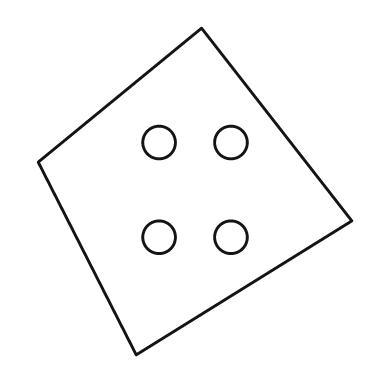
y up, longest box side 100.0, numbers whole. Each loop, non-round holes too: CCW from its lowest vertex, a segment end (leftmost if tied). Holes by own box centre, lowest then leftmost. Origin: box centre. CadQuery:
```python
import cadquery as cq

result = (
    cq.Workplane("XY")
    .moveTo(-18.0, -50.0)
    .lineTo(48.0, -9.0)
    .lineTo(2.0, 50.0)
    .lineTo(-48.0, 9.0)
    .close()
    .moveTo(-11.0, -14.0)
    .circle(5.0)
    .moveTo(11.0, -14.0)
    .circle(5.0)
    .moveTo(-11.0, 15.0)
    .circle(5.0)
    .moveTo(11.0, 15.0)
    .circle(5.0)
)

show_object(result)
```